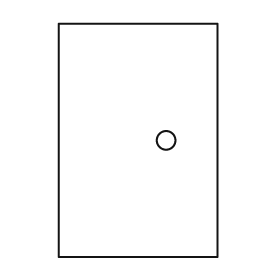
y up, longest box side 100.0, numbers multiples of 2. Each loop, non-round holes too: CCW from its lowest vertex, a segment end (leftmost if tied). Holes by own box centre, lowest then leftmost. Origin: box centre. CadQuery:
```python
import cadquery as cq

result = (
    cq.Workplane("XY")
    .moveTo(-34.0, -50.0)
    .lineTo(34.0, -50.0)
    .lineTo(34.0, 50.0)
    .lineTo(-34.0, 50.0)
    .close()
    .moveTo(12.0, 0.0)
    .circle(4.0)
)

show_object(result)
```